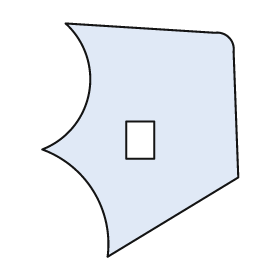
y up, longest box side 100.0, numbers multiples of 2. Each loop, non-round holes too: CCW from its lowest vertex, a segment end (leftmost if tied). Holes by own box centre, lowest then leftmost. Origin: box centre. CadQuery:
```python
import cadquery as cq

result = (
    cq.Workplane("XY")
    .moveTo(-14.0, -50.0)
    .lineTo(42.0, -16.0)
    .lineTo(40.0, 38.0)
    .threePointArc((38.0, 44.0), (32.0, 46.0))
    .lineTo(-32.0, 50.0)
    .threePointArc((-22.0, 20.0), (-42.0, -4.0))
    .threePointArc((-20.0, -22.0), (-14.0, -50.0))
    .close()
    .moveTo(-6.0, -8.0)
    .lineTo(6.0, -8.0)
    .lineTo(6.0, 8.0)
    .lineTo(-6.0, 8.0)
    .close()
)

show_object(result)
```